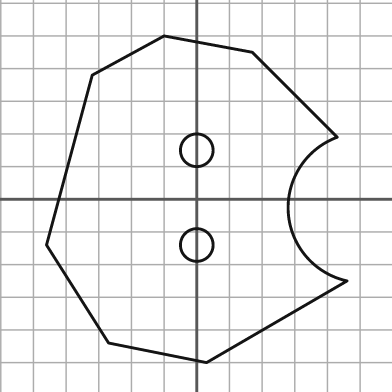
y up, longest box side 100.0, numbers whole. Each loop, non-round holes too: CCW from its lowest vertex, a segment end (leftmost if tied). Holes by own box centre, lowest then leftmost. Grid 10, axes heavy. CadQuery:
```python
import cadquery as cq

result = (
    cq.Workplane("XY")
    .moveTo(3.0, -50.0)
    .lineTo(46.0, -25.0)
    .threePointArc((28.0, -4.0), (43.0, 19.0))
    .lineTo(17.0, 45.0)
    .lineTo(-10.0, 50.0)
    .lineTo(-32.0, 38.0)
    .lineTo(-46.0, -14.0)
    .lineTo(-27.0, -44.0)
    .close()
    .moveTo(0.0, -14.0)
    .circle(5.0)
    .moveTo(0.0, 15.0)
    .circle(5.0)
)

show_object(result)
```